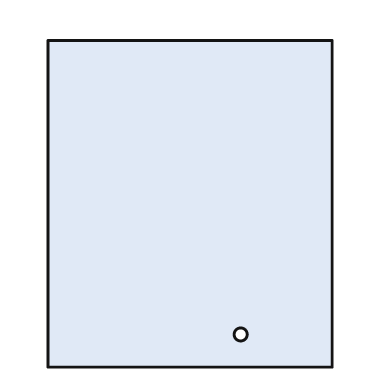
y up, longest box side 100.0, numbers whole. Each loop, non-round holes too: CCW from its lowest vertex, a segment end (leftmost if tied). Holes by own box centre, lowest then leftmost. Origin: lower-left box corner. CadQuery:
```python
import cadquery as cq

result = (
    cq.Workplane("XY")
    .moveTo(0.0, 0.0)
    .lineTo(87.0, 0.0)
    .lineTo(87.0, 100.0)
    .lineTo(0.0, 100.0)
    .close()
    .moveTo(59.0, 10.0)
    .circle(2.0)
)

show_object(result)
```